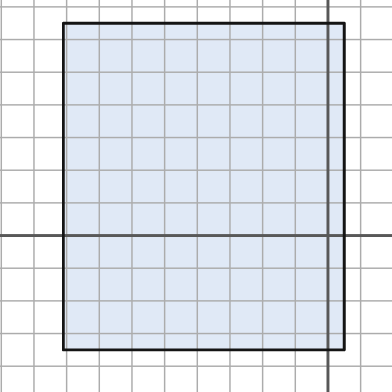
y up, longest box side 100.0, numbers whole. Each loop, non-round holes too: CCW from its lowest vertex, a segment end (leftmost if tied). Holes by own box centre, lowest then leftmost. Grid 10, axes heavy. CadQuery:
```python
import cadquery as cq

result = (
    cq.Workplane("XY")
    .moveTo(-81.0, -35.0)
    .lineTo(5.0, -35.0)
    .lineTo(5.0, 65.0)
    .lineTo(-81.0, 65.0)
    .close()
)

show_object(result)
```